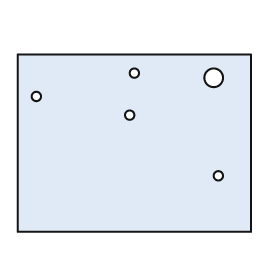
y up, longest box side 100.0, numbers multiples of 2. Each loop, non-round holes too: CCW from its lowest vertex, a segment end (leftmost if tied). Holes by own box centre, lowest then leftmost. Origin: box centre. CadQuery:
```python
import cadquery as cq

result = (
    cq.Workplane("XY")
    .moveTo(-50.0, -38.0)
    .lineTo(50.0, -38.0)
    .lineTo(50.0, 38.0)
    .lineTo(-50.0, 38.0)
    .close()
    .moveTo(36.0, -14.0)
    .circle(2.0)
    .moveTo(-2.0, 12.0)
    .circle(2.0)
    .moveTo(-42.0, 20.0)
    .circle(2.0)
    .moveTo(34.0, 28.0)
    .circle(4.0)
    .moveTo(0.0, 30.0)
    .circle(2.0)
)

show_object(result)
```